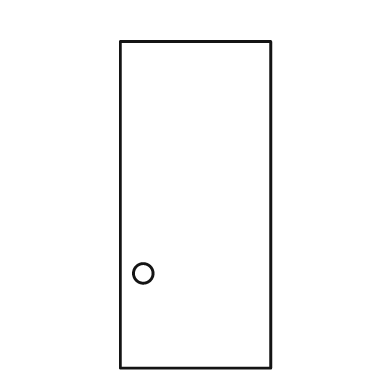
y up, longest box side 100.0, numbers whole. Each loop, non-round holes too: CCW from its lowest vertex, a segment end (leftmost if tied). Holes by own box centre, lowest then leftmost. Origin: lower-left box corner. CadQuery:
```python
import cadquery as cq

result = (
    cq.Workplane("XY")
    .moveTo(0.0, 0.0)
    .lineTo(46.0, 0.0)
    .lineTo(46.0, 100.0)
    .lineTo(0.0, 100.0)
    .close()
    .moveTo(7.0, 29.0)
    .circle(3.0)
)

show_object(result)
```